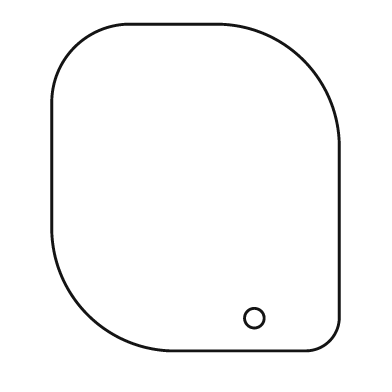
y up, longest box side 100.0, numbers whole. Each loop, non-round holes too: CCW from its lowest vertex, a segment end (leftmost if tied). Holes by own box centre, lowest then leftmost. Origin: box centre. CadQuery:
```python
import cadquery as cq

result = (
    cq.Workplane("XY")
    .moveTo(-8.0, -50.0)
    .lineTo(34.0, -50.0)
    .threePointArc((41.0, -47.0), (44.0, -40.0))
    .lineTo(44.0, 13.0)
    .threePointArc((33.0, 39.0), (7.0, 50.0))
    .lineTo(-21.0, 50.0)
    .threePointArc((-37.0, 43.0), (-44.0, 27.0))
    .lineTo(-44.0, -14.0)
    .threePointArc((-33.0, -39.0), (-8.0, -50.0))
    .close()
    .moveTo(18.0, -40.0)
    .circle(3.0)
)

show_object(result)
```